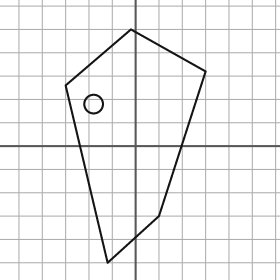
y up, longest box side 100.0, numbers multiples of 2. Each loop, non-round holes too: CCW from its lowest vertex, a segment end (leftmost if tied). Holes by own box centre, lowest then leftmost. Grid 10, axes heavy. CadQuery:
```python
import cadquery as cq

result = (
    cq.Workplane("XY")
    .moveTo(-12.0, -50.0)
    .lineTo(10.0, -30.0)
    .lineTo(30.0, 32.0)
    .lineTo(-2.0, 50.0)
    .lineTo(-30.0, 26.0)
    .close()
    .moveTo(-18.0, 18.0)
    .circle(4.0)
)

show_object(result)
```